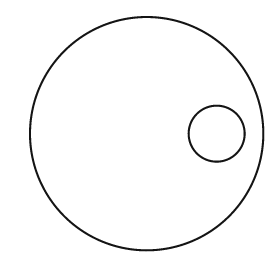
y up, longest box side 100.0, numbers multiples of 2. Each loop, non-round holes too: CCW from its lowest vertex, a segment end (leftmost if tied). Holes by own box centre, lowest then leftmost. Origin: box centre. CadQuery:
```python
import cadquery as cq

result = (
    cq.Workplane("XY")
    .moveTo(0.0, 0.0)
    .circle(50.0)
    .moveTo(30.0, 0.0)
    .circle(12.0)
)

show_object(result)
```